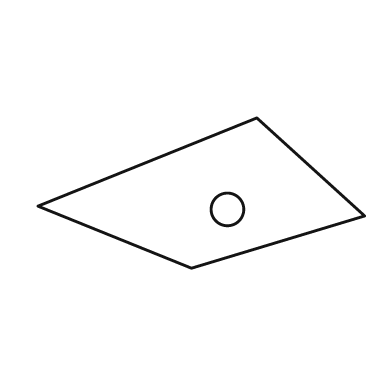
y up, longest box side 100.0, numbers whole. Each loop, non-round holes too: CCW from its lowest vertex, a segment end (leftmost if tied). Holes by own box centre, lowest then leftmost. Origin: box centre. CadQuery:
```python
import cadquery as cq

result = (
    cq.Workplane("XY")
    .moveTo(-3.0, -23.0)
    .lineTo(50.0, -7.0)
    .lineTo(17.0, 23.0)
    .lineTo(-50.0, -4.0)
    .close()
    .moveTo(8.0, -5.0)
    .circle(5.0)
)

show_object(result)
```